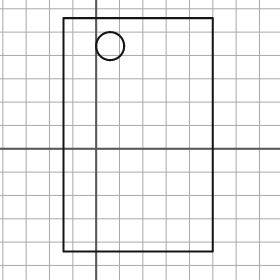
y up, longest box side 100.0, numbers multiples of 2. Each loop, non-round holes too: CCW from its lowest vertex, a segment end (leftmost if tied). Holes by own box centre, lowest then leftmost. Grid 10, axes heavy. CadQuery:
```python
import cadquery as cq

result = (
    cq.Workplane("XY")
    .moveTo(-14.0, -44.0)
    .lineTo(50.0, -44.0)
    .lineTo(50.0, 56.0)
    .lineTo(-14.0, 56.0)
    .close()
    .moveTo(6.0, 44.0)
    .circle(6.0)
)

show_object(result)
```